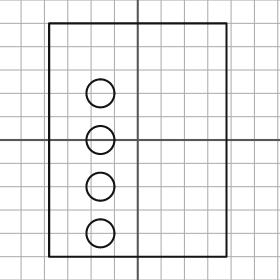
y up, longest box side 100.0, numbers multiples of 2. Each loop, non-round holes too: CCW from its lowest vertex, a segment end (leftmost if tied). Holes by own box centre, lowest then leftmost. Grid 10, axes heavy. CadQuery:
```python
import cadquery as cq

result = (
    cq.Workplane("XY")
    .moveTo(-38.0, -50.0)
    .lineTo(38.0, -50.0)
    .lineTo(38.0, 50.0)
    .lineTo(-38.0, 50.0)
    .close()
    .moveTo(-16.0, -40.0)
    .circle(6.0)
    .moveTo(-16.0, -20.0)
    .circle(6.0)
    .moveTo(-16.0, 0.0)
    .circle(6.0)
    .moveTo(-16.0, 20.0)
    .circle(6.0)
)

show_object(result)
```